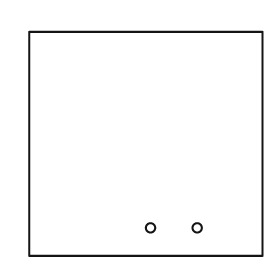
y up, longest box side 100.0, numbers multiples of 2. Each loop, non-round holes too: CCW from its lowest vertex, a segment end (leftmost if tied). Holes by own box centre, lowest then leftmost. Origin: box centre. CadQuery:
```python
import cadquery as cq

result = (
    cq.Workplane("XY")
    .moveTo(-50.0, -48.0)
    .lineTo(50.0, -48.0)
    .lineTo(50.0, 48.0)
    .lineTo(-50.0, 48.0)
    .close()
    .moveTo(2.0, -36.0)
    .circle(2.0)
    .moveTo(22.0, -36.0)
    .circle(2.0)
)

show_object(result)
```